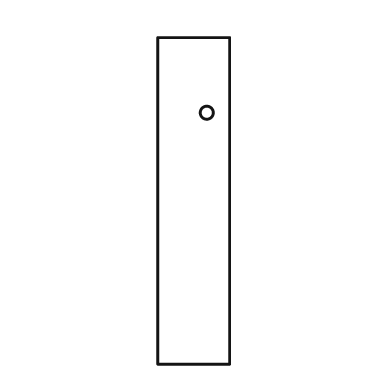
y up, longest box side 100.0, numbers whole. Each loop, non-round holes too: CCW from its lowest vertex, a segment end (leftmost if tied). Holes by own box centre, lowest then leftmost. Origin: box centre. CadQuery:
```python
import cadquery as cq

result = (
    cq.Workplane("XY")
    .moveTo(-11.0, -50.0)
    .lineTo(11.0, -50.0)
    .lineTo(11.0, 50.0)
    .lineTo(-11.0, 50.0)
    .close()
    .moveTo(4.0, 27.0)
    .circle(2.0)
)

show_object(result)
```